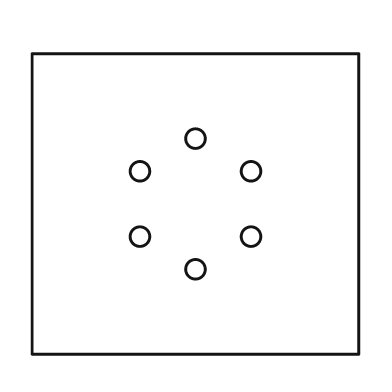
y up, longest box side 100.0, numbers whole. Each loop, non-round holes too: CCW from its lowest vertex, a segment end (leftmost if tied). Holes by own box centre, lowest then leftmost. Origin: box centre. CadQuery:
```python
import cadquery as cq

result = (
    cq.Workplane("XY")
    .moveTo(-50.0, -46.0)
    .lineTo(50.0, -46.0)
    .lineTo(50.0, 46.0)
    .lineTo(-50.0, 46.0)
    .close()
    .moveTo(0.0, -20.0)
    .circle(3.0)
    .moveTo(-17.0, -10.0)
    .circle(3.0)
    .moveTo(17.0, -10.0)
    .circle(3.0)
    .moveTo(-17.0, 10.0)
    .circle(3.0)
    .moveTo(17.0, 10.0)
    .circle(3.0)
    .moveTo(0.0, 20.0)
    .circle(3.0)
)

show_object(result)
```